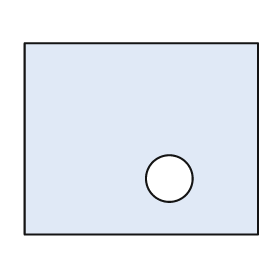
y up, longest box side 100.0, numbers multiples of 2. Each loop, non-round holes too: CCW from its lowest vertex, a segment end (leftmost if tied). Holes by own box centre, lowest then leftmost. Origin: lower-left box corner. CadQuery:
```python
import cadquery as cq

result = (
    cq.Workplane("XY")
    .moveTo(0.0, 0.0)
    .lineTo(100.0, 0.0)
    .lineTo(100.0, 82.0)
    .lineTo(0.0, 82.0)
    .close()
    .moveTo(62.0, 24.0)
    .circle(10.0)
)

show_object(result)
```